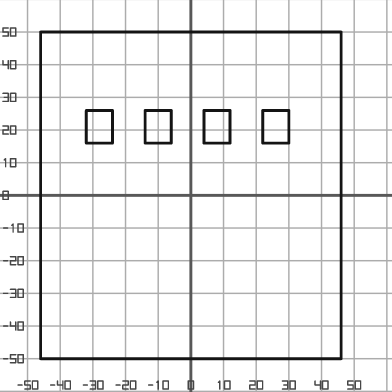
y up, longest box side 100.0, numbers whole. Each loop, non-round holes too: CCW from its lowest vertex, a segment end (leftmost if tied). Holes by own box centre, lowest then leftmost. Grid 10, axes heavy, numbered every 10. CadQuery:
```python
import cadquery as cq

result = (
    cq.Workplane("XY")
    .moveTo(-46.0, -50.0)
    .lineTo(46.0, -50.0)
    .lineTo(46.0, 50.0)
    .lineTo(-46.0, 50.0)
    .close()
    .moveTo(-32.0, 16.0)
    .lineTo(-24.0, 16.0)
    .lineTo(-24.0, 26.0)
    .lineTo(-32.0, 26.0)
    .close()
    .moveTo(-14.0, 16.0)
    .lineTo(-6.0, 16.0)
    .lineTo(-6.0, 26.0)
    .lineTo(-14.0, 26.0)
    .close()
    .moveTo(4.0, 16.0)
    .lineTo(12.0, 16.0)
    .lineTo(12.0, 26.0)
    .lineTo(4.0, 26.0)
    .close()
    .moveTo(22.0, 16.0)
    .lineTo(30.0, 16.0)
    .lineTo(30.0, 26.0)
    .lineTo(22.0, 26.0)
    .close()
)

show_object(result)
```